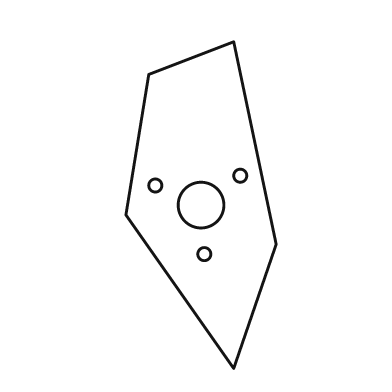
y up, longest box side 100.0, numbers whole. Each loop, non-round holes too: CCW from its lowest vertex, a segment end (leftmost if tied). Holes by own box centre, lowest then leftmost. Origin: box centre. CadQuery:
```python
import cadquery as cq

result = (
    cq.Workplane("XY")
    .moveTo(10.0, -50.0)
    .lineTo(23.0, -12.0)
    .lineTo(10.0, 50.0)
    .lineTo(-16.0, 40.0)
    .lineTo(-23.0, -3.0)
    .close()
    .moveTo(1.0, -15.0)
    .circle(2.0)
    .moveTo(0.0, 0.0)
    .circle(7.0)
    .moveTo(-14.0, 6.0)
    .circle(2.0)
    .moveTo(12.0, 9.0)
    .circle(2.0)
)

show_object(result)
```